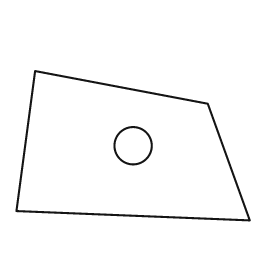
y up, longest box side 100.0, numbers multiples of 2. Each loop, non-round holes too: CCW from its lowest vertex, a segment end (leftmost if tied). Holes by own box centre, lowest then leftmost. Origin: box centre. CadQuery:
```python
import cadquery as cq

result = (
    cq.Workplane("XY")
    .moveTo(50.0, -32.0)
    .lineTo(32.0, 18.0)
    .lineTo(-42.0, 32.0)
    .lineTo(-50.0, -28.0)
    .close()
    .moveTo(0.0, 0.0)
    .circle(8.0)
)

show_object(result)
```